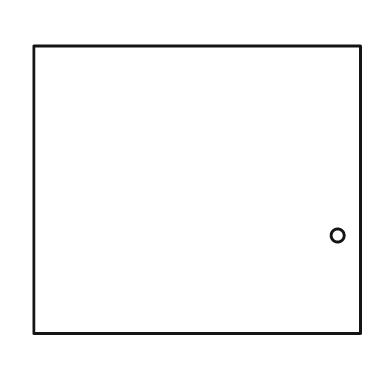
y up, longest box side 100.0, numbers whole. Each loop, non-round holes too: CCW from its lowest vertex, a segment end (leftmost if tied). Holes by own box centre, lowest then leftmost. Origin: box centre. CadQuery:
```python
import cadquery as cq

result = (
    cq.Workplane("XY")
    .moveTo(-50.0, -44.0)
    .lineTo(50.0, -44.0)
    .lineTo(50.0, 44.0)
    .lineTo(-50.0, 44.0)
    .close()
    .moveTo(43.0, -14.0)
    .circle(2.0)
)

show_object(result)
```